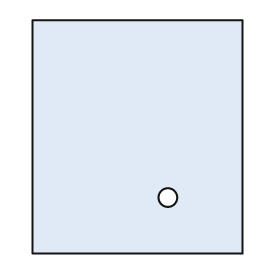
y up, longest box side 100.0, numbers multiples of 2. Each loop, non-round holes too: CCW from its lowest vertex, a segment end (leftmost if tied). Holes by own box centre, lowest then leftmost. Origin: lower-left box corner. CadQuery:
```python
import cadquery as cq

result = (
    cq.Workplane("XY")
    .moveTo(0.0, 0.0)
    .lineTo(90.0, 0.0)
    .lineTo(90.0, 100.0)
    .lineTo(0.0, 100.0)
    .close()
    .moveTo(58.0, 24.0)
    .circle(4.0)
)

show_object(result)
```